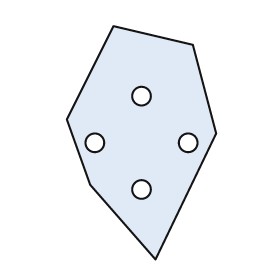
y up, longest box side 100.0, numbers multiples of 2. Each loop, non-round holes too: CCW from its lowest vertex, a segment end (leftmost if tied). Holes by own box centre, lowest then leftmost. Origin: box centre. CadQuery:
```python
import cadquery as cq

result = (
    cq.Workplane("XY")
    .moveTo(6.0, -50.0)
    .lineTo(32.0, 4.0)
    .lineTo(22.0, 42.0)
    .lineTo(-12.0, 50.0)
    .lineTo(-32.0, 10.0)
    .lineTo(-22.0, -18.0)
    .close()
    .moveTo(0.0, -20.0)
    .circle(4.0)
    .moveTo(-20.0, 0.0)
    .circle(4.0)
    .moveTo(20.0, 0.0)
    .circle(4.0)
    .moveTo(0.0, 20.0)
    .circle(4.0)
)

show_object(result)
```